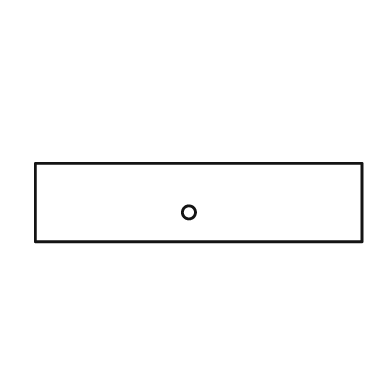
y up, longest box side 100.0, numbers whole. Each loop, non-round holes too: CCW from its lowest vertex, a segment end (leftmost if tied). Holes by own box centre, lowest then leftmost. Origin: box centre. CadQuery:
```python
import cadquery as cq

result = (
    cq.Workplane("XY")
    .moveTo(-50.0, -12.0)
    .lineTo(50.0, -12.0)
    .lineTo(50.0, 12.0)
    .lineTo(-50.0, 12.0)
    .close()
    .moveTo(-3.0, -3.0)
    .circle(2.0)
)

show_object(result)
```